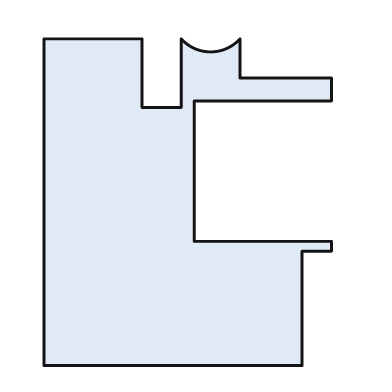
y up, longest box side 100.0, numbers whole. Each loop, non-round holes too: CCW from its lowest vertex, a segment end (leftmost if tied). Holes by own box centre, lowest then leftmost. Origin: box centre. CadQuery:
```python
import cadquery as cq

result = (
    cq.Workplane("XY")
    .moveTo(-44.0, -50.0)
    .lineTo(35.0, -50.0)
    .lineTo(35.0, -15.0)
    .lineTo(44.0, -15.0)
    .lineTo(44.0, -12.0)
    .lineTo(2.0, -12.0)
    .lineTo(2.0, 31.0)
    .lineTo(44.0, 31.0)
    .lineTo(44.0, 38.0)
    .lineTo(16.0, 38.0)
    .lineTo(16.0, 50.0)
    .threePointArc((7.0, 46.0), (-2.0, 50.0))
    .lineTo(-2.0, 29.0)
    .lineTo(-14.0, 29.0)
    .lineTo(-14.0, 50.0)
    .lineTo(-44.0, 50.0)
    .close()
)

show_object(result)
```